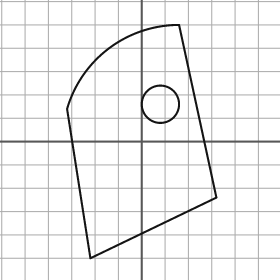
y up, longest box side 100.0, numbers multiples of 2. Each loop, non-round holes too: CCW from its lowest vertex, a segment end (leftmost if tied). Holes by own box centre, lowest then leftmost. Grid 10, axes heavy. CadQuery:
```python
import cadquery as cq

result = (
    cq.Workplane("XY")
    .moveTo(-22.0, -50.0)
    .lineTo(32.0, -24.0)
    .lineTo(16.0, 50.0)
    .threePointArc((-14.0, 40.0), (-32.0, 14.0))
    .close()
    .moveTo(8.0, 16.0)
    .circle(8.0)
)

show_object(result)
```